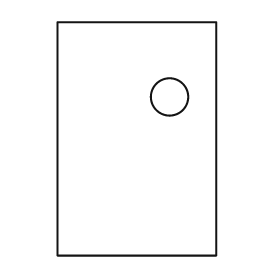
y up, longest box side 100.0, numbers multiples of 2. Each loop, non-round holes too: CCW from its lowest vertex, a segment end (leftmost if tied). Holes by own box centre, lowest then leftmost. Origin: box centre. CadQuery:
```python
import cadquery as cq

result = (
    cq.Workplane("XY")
    .moveTo(-34.0, -50.0)
    .lineTo(34.0, -50.0)
    .lineTo(34.0, 50.0)
    .lineTo(-34.0, 50.0)
    .close()
    .moveTo(14.0, 18.0)
    .circle(8.0)
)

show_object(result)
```